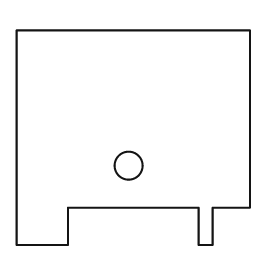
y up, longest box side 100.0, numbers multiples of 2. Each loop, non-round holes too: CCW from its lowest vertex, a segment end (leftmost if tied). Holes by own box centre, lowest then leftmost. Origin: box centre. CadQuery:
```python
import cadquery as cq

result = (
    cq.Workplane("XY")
    .moveTo(-50.0, -46.0)
    .lineTo(-28.0, -46.0)
    .lineTo(-28.0, -30.0)
    .lineTo(28.0, -30.0)
    .lineTo(28.0, -46.0)
    .lineTo(34.0, -46.0)
    .lineTo(34.0, -30.0)
    .lineTo(50.0, -30.0)
    .lineTo(50.0, 46.0)
    .lineTo(-50.0, 46.0)
    .close()
    .moveTo(-2.0, -12.0)
    .circle(6.0)
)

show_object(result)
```